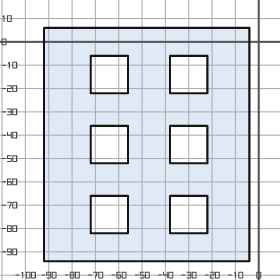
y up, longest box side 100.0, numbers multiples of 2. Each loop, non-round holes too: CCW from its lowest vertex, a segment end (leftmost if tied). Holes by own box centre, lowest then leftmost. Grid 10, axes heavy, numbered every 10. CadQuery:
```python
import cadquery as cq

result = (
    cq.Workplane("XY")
    .moveTo(-92.0, -94.0)
    .lineTo(-4.0, -94.0)
    .lineTo(-4.0, 6.0)
    .lineTo(-92.0, 6.0)
    .close()
    .moveTo(-72.0, -82.0)
    .lineTo(-56.0, -82.0)
    .lineTo(-56.0, -66.0)
    .lineTo(-72.0, -66.0)
    .close()
    .moveTo(-38.0, -82.0)
    .lineTo(-22.0, -82.0)
    .lineTo(-22.0, -66.0)
    .lineTo(-38.0, -66.0)
    .close()
    .moveTo(-72.0, -52.0)
    .lineTo(-56.0, -52.0)
    .lineTo(-56.0, -36.0)
    .lineTo(-72.0, -36.0)
    .close()
    .moveTo(-38.0, -52.0)
    .lineTo(-22.0, -52.0)
    .lineTo(-22.0, -36.0)
    .lineTo(-38.0, -36.0)
    .close()
    .moveTo(-72.0, -22.0)
    .lineTo(-56.0, -22.0)
    .lineTo(-56.0, -6.0)
    .lineTo(-72.0, -6.0)
    .close()
    .moveTo(-38.0, -22.0)
    .lineTo(-22.0, -22.0)
    .lineTo(-22.0, -6.0)
    .lineTo(-38.0, -6.0)
    .close()
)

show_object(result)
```